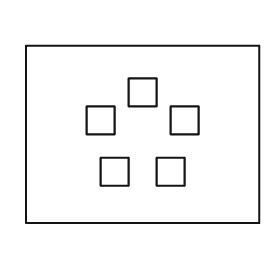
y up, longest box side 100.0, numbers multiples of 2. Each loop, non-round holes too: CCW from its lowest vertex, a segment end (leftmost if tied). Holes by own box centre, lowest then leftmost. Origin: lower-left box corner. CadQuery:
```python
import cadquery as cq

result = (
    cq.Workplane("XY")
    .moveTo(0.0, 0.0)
    .lineTo(100.0, 0.0)
    .lineTo(100.0, 76.0)
    .lineTo(0.0, 76.0)
    .close()
    .moveTo(32.0, 16.0)
    .lineTo(44.0, 16.0)
    .lineTo(44.0, 28.0)
    .lineTo(32.0, 28.0)
    .close()
    .moveTo(56.0, 16.0)
    .lineTo(68.0, 16.0)
    .lineTo(68.0, 28.0)
    .lineTo(56.0, 28.0)
    .close()
    .moveTo(26.0, 38.0)
    .lineTo(38.0, 38.0)
    .lineTo(38.0, 50.0)
    .lineTo(26.0, 50.0)
    .close()
    .moveTo(62.0, 38.0)
    .lineTo(74.0, 38.0)
    .lineTo(74.0, 50.0)
    .lineTo(62.0, 50.0)
    .close()
    .moveTo(44.0, 50.0)
    .lineTo(56.0, 50.0)
    .lineTo(56.0, 62.0)
    .lineTo(44.0, 62.0)
    .close()
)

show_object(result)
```